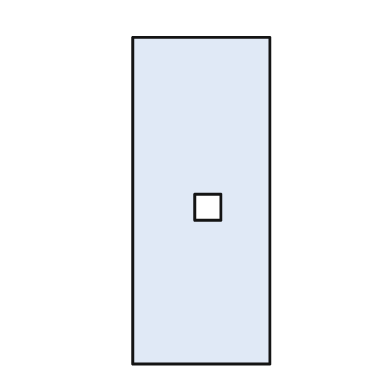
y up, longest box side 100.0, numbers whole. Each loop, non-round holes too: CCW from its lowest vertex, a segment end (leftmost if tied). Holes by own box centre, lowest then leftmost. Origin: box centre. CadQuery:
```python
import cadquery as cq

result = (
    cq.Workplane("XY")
    .moveTo(-21.0, -50.0)
    .lineTo(21.0, -50.0)
    .lineTo(21.0, 50.0)
    .lineTo(-21.0, 50.0)
    .close()
    .moveTo(-2.0, -6.0)
    .lineTo(6.0, -6.0)
    .lineTo(6.0, 2.0)
    .lineTo(-2.0, 2.0)
    .close()
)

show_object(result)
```